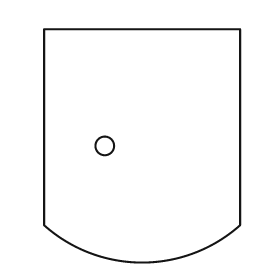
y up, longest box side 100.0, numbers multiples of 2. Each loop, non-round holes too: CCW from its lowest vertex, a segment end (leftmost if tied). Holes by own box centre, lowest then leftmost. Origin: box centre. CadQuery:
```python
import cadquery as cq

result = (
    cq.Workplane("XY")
    .moveTo(-42.0, -34.0)
    .threePointArc((0.0, -50.0), (42.0, -34.0))
    .lineTo(42.0, 50.0)
    .lineTo(-42.0, 50.0)
    .close()
    .moveTo(-16.0, 0.0)
    .circle(4.0)
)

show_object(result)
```